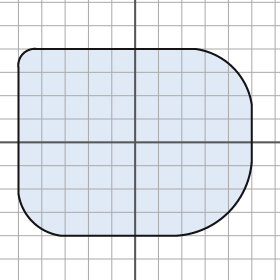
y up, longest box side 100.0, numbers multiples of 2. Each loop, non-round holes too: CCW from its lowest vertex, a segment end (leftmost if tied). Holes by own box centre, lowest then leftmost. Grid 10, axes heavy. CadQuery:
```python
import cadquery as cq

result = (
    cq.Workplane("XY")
    .moveTo(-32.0, -40.0)
    .lineTo(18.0, -40.0)
    .threePointArc((40.0, -30.0), (50.0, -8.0))
    .lineTo(50.0, 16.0)
    .threePointArc((42.0, 32.0), (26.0, 40.0))
    .lineTo(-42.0, 40.0)
    .threePointArc((-48.0, 38.0), (-50.0, 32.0))
    .lineTo(-50.0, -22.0)
    .threePointArc((-44.0, -34.0), (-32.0, -40.0))
    .close()
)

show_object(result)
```